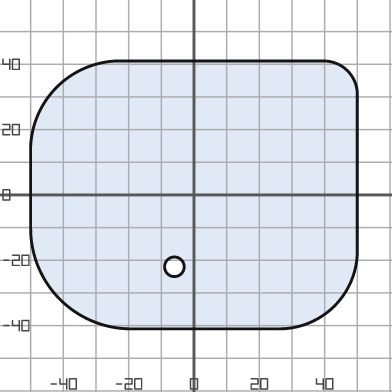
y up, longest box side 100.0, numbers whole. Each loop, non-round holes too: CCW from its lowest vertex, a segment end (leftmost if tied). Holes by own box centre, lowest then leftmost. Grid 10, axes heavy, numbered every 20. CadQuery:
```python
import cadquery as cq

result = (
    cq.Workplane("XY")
    .moveTo(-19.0, -41.0)
    .lineTo(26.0, -41.0)
    .threePointArc((43.0, -34.0), (50.0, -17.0))
    .lineTo(50.0, 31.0)
    .threePointArc((47.0, 38.0), (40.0, 41.0))
    .lineTo(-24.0, 41.0)
    .threePointArc((-42.0, 33.0), (-50.0, 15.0))
    .lineTo(-50.0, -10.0)
    .threePointArc((-41.0, -32.0), (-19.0, -41.0))
    .close()
    .moveTo(-6.0, -22.0)
    .circle(3.0)
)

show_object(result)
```